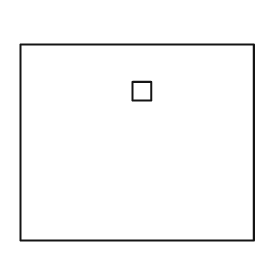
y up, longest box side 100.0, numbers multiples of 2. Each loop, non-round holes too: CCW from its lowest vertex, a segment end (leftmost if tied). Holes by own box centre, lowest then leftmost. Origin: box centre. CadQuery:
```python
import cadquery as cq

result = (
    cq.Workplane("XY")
    .moveTo(-50.0, -42.0)
    .lineTo(50.0, -42.0)
    .lineTo(50.0, 42.0)
    .lineTo(-50.0, 42.0)
    .close()
    .moveTo(-2.0, 18.0)
    .lineTo(6.0, 18.0)
    .lineTo(6.0, 26.0)
    .lineTo(-2.0, 26.0)
    .close()
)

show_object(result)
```